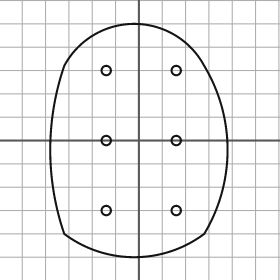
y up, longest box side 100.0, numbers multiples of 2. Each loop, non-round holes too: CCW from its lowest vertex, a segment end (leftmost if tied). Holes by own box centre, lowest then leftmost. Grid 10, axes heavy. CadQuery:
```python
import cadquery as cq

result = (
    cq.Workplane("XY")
    .moveTo(-32.0, -40.0)
    .threePointArc((-2.0, -50.0), (28.0, -40.0))
    .threePointArc((38.0, -4.0), (28.0, 32.0))
    .threePointArc((-2.0, 50.0), (-32.0, 32.0))
    .threePointArc((-38.0, -4.0), (-32.0, -40.0))
    .close()
    .moveTo(-14.0, -30.0)
    .circle(2.0)
    .moveTo(16.0, -30.0)
    .circle(2.0)
    .moveTo(-14.0, 0.0)
    .circle(2.0)
    .moveTo(16.0, 0.0)
    .circle(2.0)
    .moveTo(-14.0, 30.0)
    .circle(2.0)
    .moveTo(16.0, 30.0)
    .circle(2.0)
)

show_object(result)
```